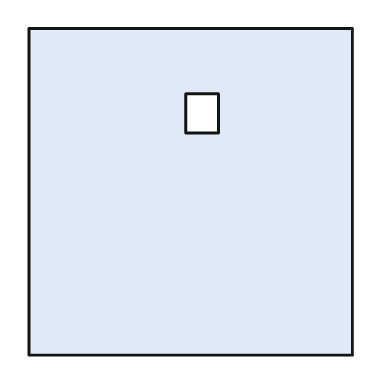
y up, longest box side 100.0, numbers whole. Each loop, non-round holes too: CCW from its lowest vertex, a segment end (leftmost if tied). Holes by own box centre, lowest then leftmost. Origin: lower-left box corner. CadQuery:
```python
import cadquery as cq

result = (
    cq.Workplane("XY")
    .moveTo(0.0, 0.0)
    .lineTo(99.0, 0.0)
    .lineTo(99.0, 100.0)
    .lineTo(0.0, 100.0)
    .close()
    .moveTo(48.0, 68.0)
    .lineTo(58.0, 68.0)
    .lineTo(58.0, 80.0)
    .lineTo(48.0, 80.0)
    .close()
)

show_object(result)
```